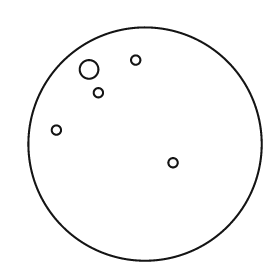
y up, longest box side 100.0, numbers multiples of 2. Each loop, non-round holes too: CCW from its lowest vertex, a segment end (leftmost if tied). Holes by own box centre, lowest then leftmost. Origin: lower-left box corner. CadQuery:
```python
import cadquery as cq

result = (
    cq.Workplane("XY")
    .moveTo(50.0, 50.0)
    .circle(50.0)
    .moveTo(62.0, 42.0)
    .circle(2.0)
    .moveTo(12.0, 56.0)
    .circle(2.0)
    .moveTo(30.0, 72.0)
    .circle(2.0)
    .moveTo(26.0, 82.0)
    .circle(4.0)
    .moveTo(46.0, 86.0)
    .circle(2.0)
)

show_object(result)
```